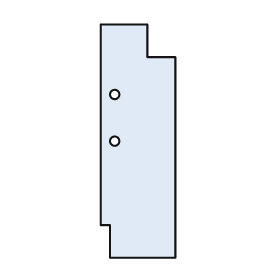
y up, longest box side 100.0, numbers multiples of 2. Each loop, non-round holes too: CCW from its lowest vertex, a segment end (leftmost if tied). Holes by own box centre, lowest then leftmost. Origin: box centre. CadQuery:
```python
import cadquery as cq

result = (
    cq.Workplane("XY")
    .moveTo(-12.0, -50.0)
    .lineTo(16.0, -50.0)
    .lineTo(16.0, 36.0)
    .lineTo(4.0, 36.0)
    .lineTo(4.0, 50.0)
    .lineTo(-16.0, 50.0)
    .lineTo(-16.0, -36.0)
    .lineTo(-12.0, -36.0)
    .close()
    .moveTo(-10.0, 0.0)
    .circle(2.0)
    .moveTo(-10.0, 20.0)
    .circle(2.0)
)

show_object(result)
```